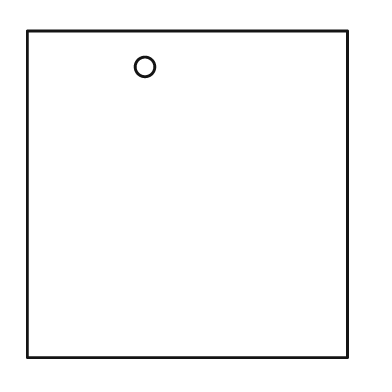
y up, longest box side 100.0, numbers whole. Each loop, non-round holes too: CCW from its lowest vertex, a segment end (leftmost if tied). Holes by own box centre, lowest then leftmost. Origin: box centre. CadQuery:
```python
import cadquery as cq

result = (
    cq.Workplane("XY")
    .moveTo(-49.0, -50.0)
    .lineTo(49.0, -50.0)
    .lineTo(49.0, 50.0)
    .lineTo(-49.0, 50.0)
    .close()
    .moveTo(-13.0, 39.0)
    .circle(3.0)
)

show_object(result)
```